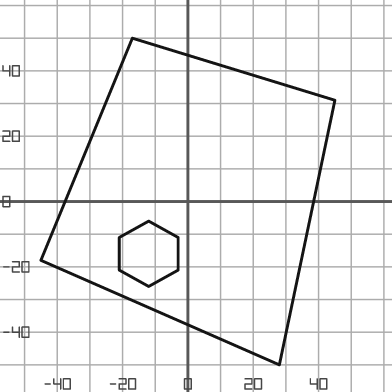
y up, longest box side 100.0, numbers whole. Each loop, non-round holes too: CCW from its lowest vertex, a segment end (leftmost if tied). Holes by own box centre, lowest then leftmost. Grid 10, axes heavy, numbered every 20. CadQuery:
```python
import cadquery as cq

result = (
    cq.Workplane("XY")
    .moveTo(28.0, -50.0)
    .lineTo(45.0, 31.0)
    .lineTo(-17.0, 50.0)
    .lineTo(-45.0, -18.0)
    .close()
    .moveTo(-12.0, -26.0)
    .lineTo(-3.0, -21.0)
    .lineTo(-3.0, -11.0)
    .lineTo(-12.0, -6.0)
    .lineTo(-21.0, -11.0)
    .lineTo(-21.0, -21.0)
    .close()
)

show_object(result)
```